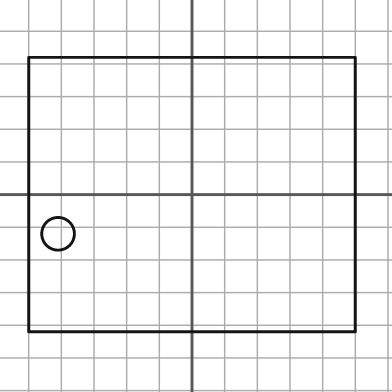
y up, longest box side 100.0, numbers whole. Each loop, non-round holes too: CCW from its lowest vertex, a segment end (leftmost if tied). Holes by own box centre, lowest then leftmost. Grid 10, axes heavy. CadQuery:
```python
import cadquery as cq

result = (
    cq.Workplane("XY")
    .moveTo(-50.0, -42.0)
    .lineTo(50.0, -42.0)
    .lineTo(50.0, 42.0)
    .lineTo(-50.0, 42.0)
    .close()
    .moveTo(-41.0, -12.0)
    .circle(5.0)
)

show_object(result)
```